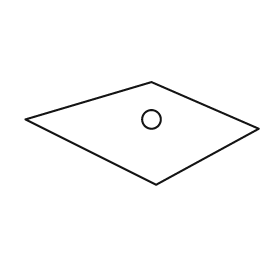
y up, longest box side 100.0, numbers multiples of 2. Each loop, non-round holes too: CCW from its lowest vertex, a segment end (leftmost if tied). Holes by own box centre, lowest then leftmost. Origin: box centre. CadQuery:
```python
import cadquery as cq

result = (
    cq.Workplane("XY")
    .moveTo(6.0, -22.0)
    .lineTo(50.0, 2.0)
    .lineTo(4.0, 22.0)
    .lineTo(-50.0, 6.0)
    .close()
    .moveTo(4.0, 6.0)
    .circle(4.0)
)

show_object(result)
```